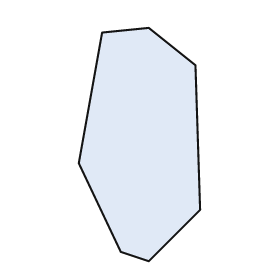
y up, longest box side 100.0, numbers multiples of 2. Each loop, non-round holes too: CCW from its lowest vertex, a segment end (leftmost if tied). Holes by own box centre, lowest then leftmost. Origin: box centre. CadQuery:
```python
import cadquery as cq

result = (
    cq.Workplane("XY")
    .moveTo(4.0, -50.0)
    .lineTo(26.0, -28.0)
    .lineTo(24.0, 34.0)
    .lineTo(4.0, 50.0)
    .lineTo(-16.0, 48.0)
    .lineTo(-26.0, -8.0)
    .lineTo(-8.0, -46.0)
    .close()
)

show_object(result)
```